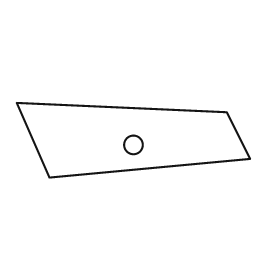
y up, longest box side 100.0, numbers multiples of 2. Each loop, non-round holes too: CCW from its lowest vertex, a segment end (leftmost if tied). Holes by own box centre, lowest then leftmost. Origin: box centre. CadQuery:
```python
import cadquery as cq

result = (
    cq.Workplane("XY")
    .moveTo(-36.0, -16.0)
    .lineTo(50.0, -8.0)
    .lineTo(40.0, 12.0)
    .lineTo(-50.0, 16.0)
    .close()
    .moveTo(0.0, -2.0)
    .circle(4.0)
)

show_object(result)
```